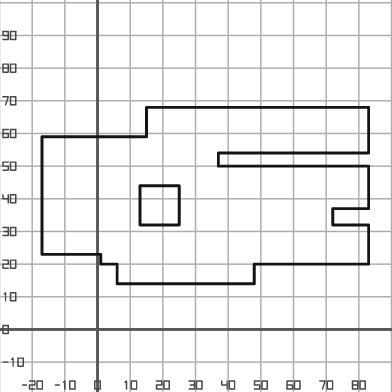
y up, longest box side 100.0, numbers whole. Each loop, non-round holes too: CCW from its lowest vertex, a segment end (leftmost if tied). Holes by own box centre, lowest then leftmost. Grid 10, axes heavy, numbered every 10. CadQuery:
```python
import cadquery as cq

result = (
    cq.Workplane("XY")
    .moveTo(6.0, 14.0)
    .lineTo(48.0, 14.0)
    .lineTo(48.0, 20.0)
    .lineTo(83.0, 20.0)
    .lineTo(83.0, 32.0)
    .lineTo(72.0, 32.0)
    .lineTo(72.0, 37.0)
    .lineTo(83.0, 37.0)
    .lineTo(83.0, 50.0)
    .lineTo(37.0, 50.0)
    .lineTo(37.0, 54.0)
    .lineTo(83.0, 54.0)
    .lineTo(83.0, 68.0)
    .lineTo(15.0, 68.0)
    .lineTo(15.0, 59.0)
    .lineTo(-17.0, 59.0)
    .lineTo(-17.0, 23.0)
    .lineTo(1.0, 23.0)
    .lineTo(1.0, 20.0)
    .lineTo(6.0, 20.0)
    .close()
    .moveTo(13.0, 32.0)
    .lineTo(25.0, 32.0)
    .lineTo(25.0, 44.0)
    .lineTo(13.0, 44.0)
    .close()
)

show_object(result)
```